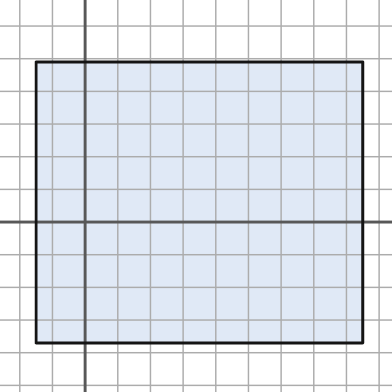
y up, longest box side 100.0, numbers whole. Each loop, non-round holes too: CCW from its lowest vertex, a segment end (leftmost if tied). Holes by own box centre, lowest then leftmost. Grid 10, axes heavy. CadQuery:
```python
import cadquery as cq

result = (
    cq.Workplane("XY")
    .moveTo(-15.0, -37.0)
    .lineTo(85.0, -37.0)
    .lineTo(85.0, 49.0)
    .lineTo(-15.0, 49.0)
    .close()
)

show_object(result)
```